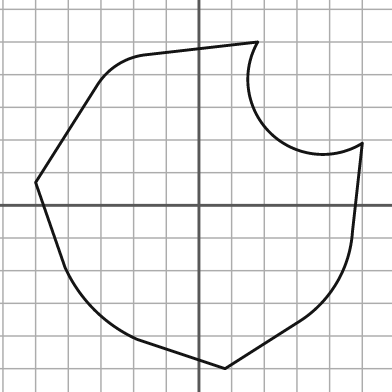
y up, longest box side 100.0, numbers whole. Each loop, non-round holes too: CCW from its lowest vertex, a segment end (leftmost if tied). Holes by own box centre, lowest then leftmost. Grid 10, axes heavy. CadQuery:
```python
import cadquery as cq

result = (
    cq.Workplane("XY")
    .moveTo(8.0, -50.0)
    .lineTo(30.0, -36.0)
    .threePointArc((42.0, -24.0), (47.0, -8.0))
    .lineTo(50.0, 19.0)
    .threePointArc((22.0, 22.0), (18.0, 50.0))
    .lineTo(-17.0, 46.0)
    .threePointArc((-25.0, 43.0), (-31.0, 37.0))
    .lineTo(-50.0, 7.0)
    .lineTo(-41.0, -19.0)
    .threePointArc((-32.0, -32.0), (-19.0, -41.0))
    .close()
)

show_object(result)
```